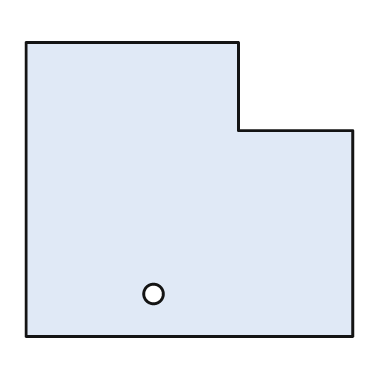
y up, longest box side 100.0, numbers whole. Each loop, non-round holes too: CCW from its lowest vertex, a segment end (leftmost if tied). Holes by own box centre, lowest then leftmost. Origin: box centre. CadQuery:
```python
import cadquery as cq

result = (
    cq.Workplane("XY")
    .moveTo(-50.0, -45.0)
    .lineTo(50.0, -45.0)
    .lineTo(50.0, 18.0)
    .lineTo(15.0, 18.0)
    .lineTo(15.0, 45.0)
    .lineTo(-50.0, 45.0)
    .close()
    .moveTo(-11.0, -32.0)
    .circle(3.0)
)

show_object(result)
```